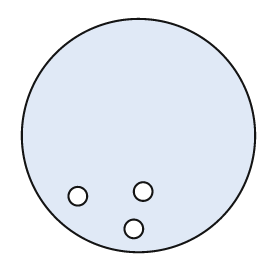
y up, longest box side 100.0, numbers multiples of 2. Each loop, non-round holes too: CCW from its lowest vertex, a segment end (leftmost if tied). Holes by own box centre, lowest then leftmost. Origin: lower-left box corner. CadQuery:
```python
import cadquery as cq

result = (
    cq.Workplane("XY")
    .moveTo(50.0, 50.0)
    .circle(50.0)
    .moveTo(48.0, 10.0)
    .circle(4.0)
    .moveTo(24.0, 24.0)
    .circle(4.0)
    .moveTo(52.0, 26.0)
    .circle(4.0)
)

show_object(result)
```